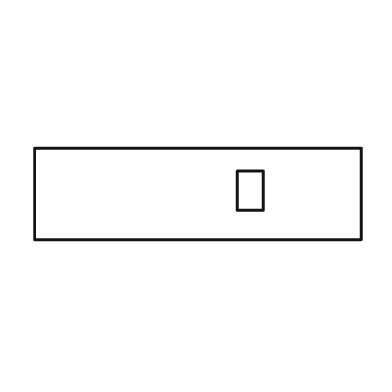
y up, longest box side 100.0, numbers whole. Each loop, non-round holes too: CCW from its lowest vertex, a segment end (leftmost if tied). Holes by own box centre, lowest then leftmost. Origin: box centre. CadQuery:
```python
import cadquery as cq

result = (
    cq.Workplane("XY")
    .moveTo(-50.0, -14.0)
    .lineTo(50.0, -14.0)
    .lineTo(50.0, 14.0)
    .lineTo(-50.0, 14.0)
    .close()
    .moveTo(12.0, -5.0)
    .lineTo(20.0, -5.0)
    .lineTo(20.0, 7.0)
    .lineTo(12.0, 7.0)
    .close()
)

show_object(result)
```